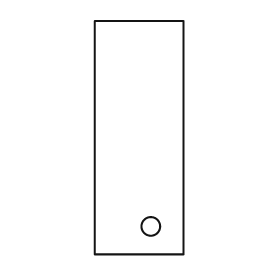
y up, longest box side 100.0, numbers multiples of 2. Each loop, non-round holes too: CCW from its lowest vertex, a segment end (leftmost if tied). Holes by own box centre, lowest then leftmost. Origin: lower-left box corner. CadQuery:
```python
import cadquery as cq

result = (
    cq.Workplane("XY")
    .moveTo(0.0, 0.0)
    .lineTo(38.0, 0.0)
    .lineTo(38.0, 100.0)
    .lineTo(0.0, 100.0)
    .close()
    .moveTo(24.0, 12.0)
    .circle(4.0)
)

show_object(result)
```